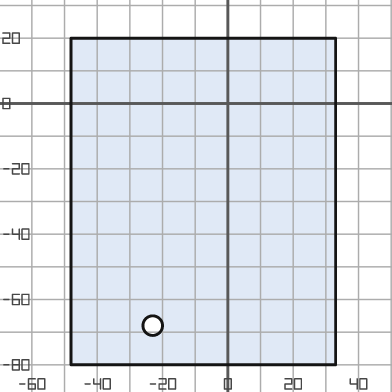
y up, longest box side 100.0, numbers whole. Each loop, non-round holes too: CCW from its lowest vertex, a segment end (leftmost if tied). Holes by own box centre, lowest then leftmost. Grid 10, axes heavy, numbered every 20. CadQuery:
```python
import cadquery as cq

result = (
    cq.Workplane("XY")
    .moveTo(-48.0, -80.0)
    .lineTo(33.0, -80.0)
    .lineTo(33.0, 20.0)
    .lineTo(-48.0, 20.0)
    .close()
    .moveTo(-23.0, -68.0)
    .circle(3.0)
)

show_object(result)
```